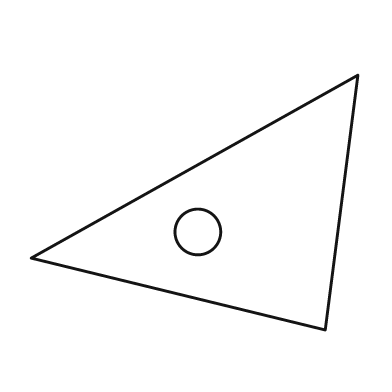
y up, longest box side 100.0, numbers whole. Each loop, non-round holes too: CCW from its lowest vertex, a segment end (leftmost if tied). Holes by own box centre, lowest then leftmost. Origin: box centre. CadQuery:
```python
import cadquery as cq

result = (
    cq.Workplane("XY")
    .moveTo(40.0, -39.0)
    .lineTo(50.0, 39.0)
    .lineTo(-50.0, -17.0)
    .close()
    .moveTo(1.0, -9.0)
    .circle(7.0)
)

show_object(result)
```